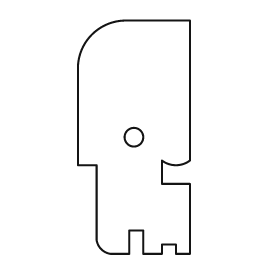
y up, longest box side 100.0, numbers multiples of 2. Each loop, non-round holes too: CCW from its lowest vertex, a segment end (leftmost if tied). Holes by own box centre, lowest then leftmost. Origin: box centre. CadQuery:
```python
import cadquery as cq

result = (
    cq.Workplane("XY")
    .moveTo(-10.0, -50.0)
    .lineTo(-2.0, -50.0)
    .lineTo(-2.0, -40.0)
    .lineTo(4.0, -40.0)
    .lineTo(4.0, -50.0)
    .lineTo(12.0, -50.0)
    .lineTo(12.0, -46.0)
    .lineTo(18.0, -46.0)
    .lineTo(18.0, -50.0)
    .lineTo(24.0, -50.0)
    .lineTo(24.0, -20.0)
    .lineTo(12.0, -20.0)
    .lineTo(12.0, -10.0)
    .threePointArc((18.0, -12.0), (24.0, -10.0))
    .lineTo(24.0, 50.0)
    .lineTo(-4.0, 50.0)
    .threePointArc((-18.0, 44.0), (-24.0, 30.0))
    .lineTo(-24.0, -12.0)
    .lineTo(-16.0, -12.0)
    .lineTo(-16.0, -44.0)
    .threePointArc((-14.0, -48.0), (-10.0, -50.0))
    .close()
    .moveTo(0.0, 0.0)
    .circle(4.0)
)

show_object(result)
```